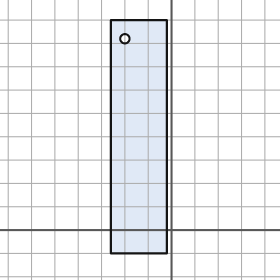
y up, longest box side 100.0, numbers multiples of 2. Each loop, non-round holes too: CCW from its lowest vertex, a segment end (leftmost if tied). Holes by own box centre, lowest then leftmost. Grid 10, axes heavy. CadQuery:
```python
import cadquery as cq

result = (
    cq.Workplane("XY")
    .moveTo(-26.0, -10.0)
    .lineTo(-2.0, -10.0)
    .lineTo(-2.0, 90.0)
    .lineTo(-26.0, 90.0)
    .close()
    .moveTo(-20.0, 82.0)
    .circle(2.0)
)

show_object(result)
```